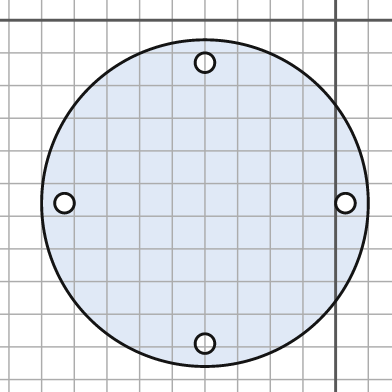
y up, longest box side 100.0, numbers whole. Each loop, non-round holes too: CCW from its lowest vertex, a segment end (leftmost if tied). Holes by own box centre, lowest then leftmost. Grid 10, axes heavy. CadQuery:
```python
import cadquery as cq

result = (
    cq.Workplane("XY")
    .moveTo(-40.0, -56.0)
    .circle(50.0)
    .moveTo(-40.0, -99.0)
    .circle(3.0)
    .moveTo(-83.0, -56.0)
    .circle(3.0)
    .moveTo(3.0, -56.0)
    .circle(3.0)
    .moveTo(-40.0, -13.0)
    .circle(3.0)
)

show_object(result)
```